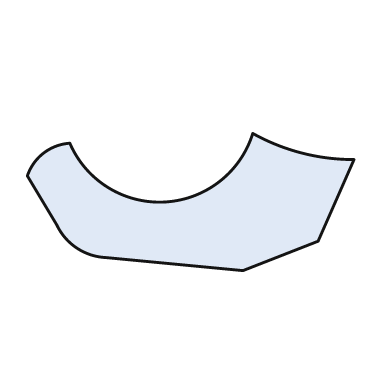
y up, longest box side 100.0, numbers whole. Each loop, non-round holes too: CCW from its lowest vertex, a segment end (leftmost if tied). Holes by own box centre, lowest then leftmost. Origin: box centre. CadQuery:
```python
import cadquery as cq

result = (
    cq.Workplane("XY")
    .moveTo(16.0, -21.0)
    .lineTo(39.0, -12.0)
    .lineTo(50.0, 13.0)
    .threePointArc((34.0, 15.0), (19.0, 21.0))
    .threePointArc((-8.0, 0.0), (-37.0, 18.0))
    .threePointArc((-45.0, 15.0), (-50.0, 8.0))
    .lineTo(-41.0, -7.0)
    .threePointArc((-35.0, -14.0), (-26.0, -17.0))
    .close()
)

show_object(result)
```